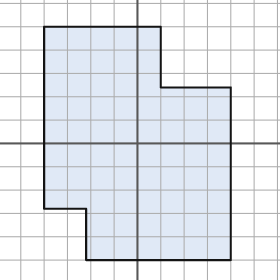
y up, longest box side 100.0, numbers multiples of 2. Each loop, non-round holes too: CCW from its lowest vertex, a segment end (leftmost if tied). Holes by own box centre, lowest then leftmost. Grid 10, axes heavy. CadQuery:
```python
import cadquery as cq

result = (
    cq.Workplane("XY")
    .moveTo(-22.0, -50.0)
    .lineTo(40.0, -50.0)
    .lineTo(40.0, 24.0)
    .lineTo(10.0, 24.0)
    .lineTo(10.0, 50.0)
    .lineTo(-40.0, 50.0)
    .lineTo(-40.0, -28.0)
    .lineTo(-22.0, -28.0)
    .close()
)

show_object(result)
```